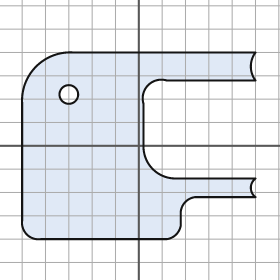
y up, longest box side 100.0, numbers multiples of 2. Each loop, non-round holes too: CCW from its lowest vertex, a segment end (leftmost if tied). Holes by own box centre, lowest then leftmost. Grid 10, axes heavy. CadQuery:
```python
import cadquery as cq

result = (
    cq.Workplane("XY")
    .moveTo(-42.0, -40.0)
    .lineTo(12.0, -40.0)
    .threePointArc((16.0, -38.0), (18.0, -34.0))
    .lineTo(18.0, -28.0)
    .threePointArc((20.0, -24.0), (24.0, -22.0))
    .lineTo(50.0, -22.0)
    .threePointArc((48.0, -18.0), (50.0, -14.0))
    .lineTo(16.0, -14.0)
    .threePointArc((6.0, -10.0), (2.0, 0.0))
    .lineTo(2.0, 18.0)
    .threePointArc((4.0, 26.0), (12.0, 28.0))
    .lineTo(50.0, 28.0)
    .threePointArc((48.0, 34.0), (50.0, 40.0))
    .lineTo(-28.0, 40.0)
    .threePointArc((-44.0, 34.0), (-50.0, 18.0))
    .lineTo(-50.0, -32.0)
    .threePointArc((-48.0, -38.0), (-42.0, -40.0))
    .close()
    .moveTo(-30.0, 22.0)
    .circle(4.0)
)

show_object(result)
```